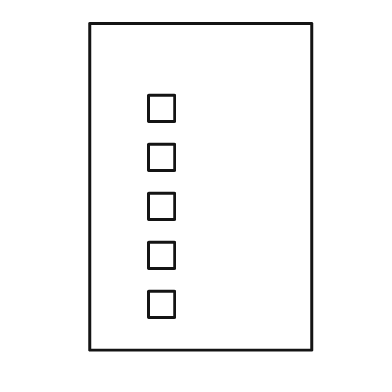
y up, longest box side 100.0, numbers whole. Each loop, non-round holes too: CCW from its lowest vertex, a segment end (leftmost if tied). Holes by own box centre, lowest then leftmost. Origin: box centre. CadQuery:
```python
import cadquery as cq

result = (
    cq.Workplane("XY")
    .moveTo(-34.0, -50.0)
    .lineTo(34.0, -50.0)
    .lineTo(34.0, 50.0)
    .lineTo(-34.0, 50.0)
    .close()
    .moveTo(-16.0, -40.0)
    .lineTo(-8.0, -40.0)
    .lineTo(-8.0, -32.0)
    .lineTo(-16.0, -32.0)
    .close()
    .moveTo(-16.0, -25.0)
    .lineTo(-8.0, -25.0)
    .lineTo(-8.0, -17.0)
    .lineTo(-16.0, -17.0)
    .close()
    .moveTo(-16.0, -10.0)
    .lineTo(-8.0, -10.0)
    .lineTo(-8.0, -2.0)
    .lineTo(-16.0, -2.0)
    .close()
    .moveTo(-16.0, 5.0)
    .lineTo(-8.0, 5.0)
    .lineTo(-8.0, 13.0)
    .lineTo(-16.0, 13.0)
    .close()
    .moveTo(-16.0, 20.0)
    .lineTo(-8.0, 20.0)
    .lineTo(-8.0, 28.0)
    .lineTo(-16.0, 28.0)
    .close()
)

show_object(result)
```